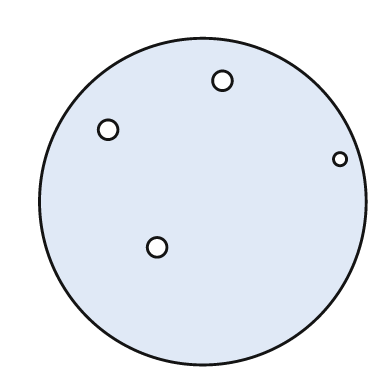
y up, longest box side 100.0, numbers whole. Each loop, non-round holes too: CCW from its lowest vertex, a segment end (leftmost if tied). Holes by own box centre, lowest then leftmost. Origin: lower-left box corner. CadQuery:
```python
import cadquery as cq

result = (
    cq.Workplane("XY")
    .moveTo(50.0, 50.0)
    .circle(50.0)
    .moveTo(36.0, 36.0)
    .circle(3.0)
    .moveTo(92.0, 63.0)
    .circle(2.0)
    .moveTo(21.0, 72.0)
    .circle(3.0)
    .moveTo(56.0, 87.0)
    .circle(3.0)
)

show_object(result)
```